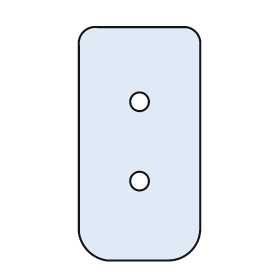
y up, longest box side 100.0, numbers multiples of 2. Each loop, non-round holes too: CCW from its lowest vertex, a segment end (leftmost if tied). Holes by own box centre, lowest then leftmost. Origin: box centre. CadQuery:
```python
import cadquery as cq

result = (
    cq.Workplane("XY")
    .moveTo(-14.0, -50.0)
    .lineTo(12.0, -50.0)
    .threePointArc((22.0, -46.0), (26.0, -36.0))
    .lineTo(26.0, 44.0)
    .threePointArc((24.0, 48.0), (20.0, 50.0))
    .lineTo(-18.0, 50.0)
    .threePointArc((-24.0, 48.0), (-26.0, 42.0))
    .lineTo(-26.0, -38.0)
    .threePointArc((-22.0, -46.0), (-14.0, -50.0))
    .close()
    .moveTo(0.0, -16.0)
    .circle(4.0)
    .moveTo(0.0, 18.0)
    .circle(4.0)
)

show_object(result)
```